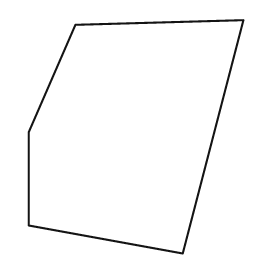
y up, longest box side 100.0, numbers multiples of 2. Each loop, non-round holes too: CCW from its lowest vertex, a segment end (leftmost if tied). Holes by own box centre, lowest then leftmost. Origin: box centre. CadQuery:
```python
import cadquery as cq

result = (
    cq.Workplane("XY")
    .moveTo(20.0, -50.0)
    .lineTo(46.0, 50.0)
    .lineTo(-26.0, 48.0)
    .lineTo(-46.0, 2.0)
    .lineTo(-46.0, -38.0)
    .close()
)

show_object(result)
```